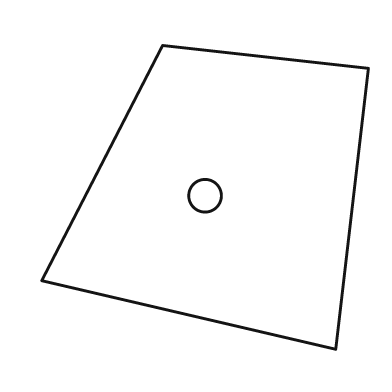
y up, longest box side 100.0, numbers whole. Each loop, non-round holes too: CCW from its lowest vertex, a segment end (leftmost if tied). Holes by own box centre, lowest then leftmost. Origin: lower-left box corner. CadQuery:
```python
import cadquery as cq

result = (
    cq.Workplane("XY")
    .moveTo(90.0, 0.0)
    .lineTo(100.0, 86.0)
    .lineTo(37.0, 93.0)
    .lineTo(0.0, 21.0)
    .close()
    .moveTo(50.0, 47.0)
    .circle(5.0)
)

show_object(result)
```